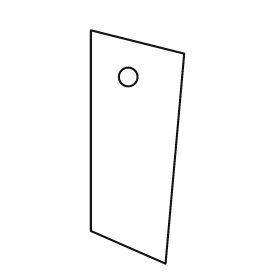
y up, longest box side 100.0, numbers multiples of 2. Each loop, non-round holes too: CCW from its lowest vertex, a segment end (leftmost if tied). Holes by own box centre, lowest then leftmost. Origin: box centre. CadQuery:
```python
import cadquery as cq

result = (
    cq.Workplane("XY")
    .moveTo(12.0, -50.0)
    .lineTo(20.0, 40.0)
    .lineTo(-20.0, 50.0)
    .lineTo(-20.0, -36.0)
    .close()
    .moveTo(-4.0, 30.0)
    .circle(4.0)
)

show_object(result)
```